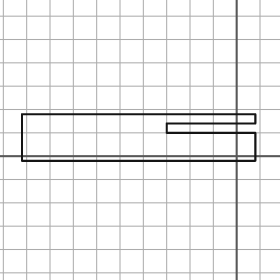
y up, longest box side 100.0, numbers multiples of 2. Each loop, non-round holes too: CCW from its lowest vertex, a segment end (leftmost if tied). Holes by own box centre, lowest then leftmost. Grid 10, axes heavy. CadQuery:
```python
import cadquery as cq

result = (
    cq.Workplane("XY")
    .moveTo(-92.0, -2.0)
    .lineTo(8.0, -2.0)
    .lineTo(8.0, 10.0)
    .lineTo(-30.0, 10.0)
    .lineTo(-30.0, 14.0)
    .lineTo(8.0, 14.0)
    .lineTo(8.0, 18.0)
    .lineTo(-92.0, 18.0)
    .close()
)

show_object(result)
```